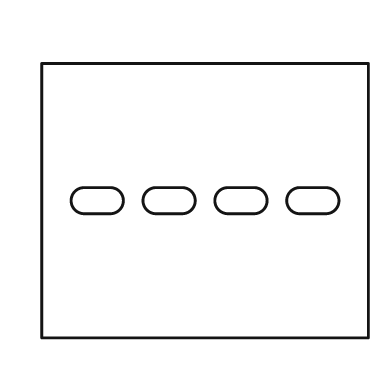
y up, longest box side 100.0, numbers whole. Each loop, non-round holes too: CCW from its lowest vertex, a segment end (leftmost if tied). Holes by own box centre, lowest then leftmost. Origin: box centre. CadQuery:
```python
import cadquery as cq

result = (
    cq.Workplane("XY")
    .moveTo(-50.0, -42.0)
    .lineTo(50.0, -42.0)
    .lineTo(50.0, 42.0)
    .lineTo(-50.0, 42.0)
    .close()
    .moveTo(-37.0, -4.0)
    .lineTo(-29.0, -4.0)
    .threePointArc((-25.0, 0.0), (-29.0, 4.0))
    .lineTo(-37.0, 4.0)
    .threePointArc((-41.0, 0.0), (-37.0, -4.0))
    .close()
    .moveTo(-15.0, -4.0)
    .lineTo(-7.0, -4.0)
    .threePointArc((-3.0, 0.0), (-7.0, 4.0))
    .lineTo(-15.0, 4.0)
    .threePointArc((-19.0, 0.0), (-15.0, -4.0))
    .close()
    .moveTo(7.0, -4.0)
    .lineTo(15.0, -4.0)
    .threePointArc((19.0, 0.0), (15.0, 4.0))
    .lineTo(7.0, 4.0)
    .threePointArc((3.0, 0.0), (7.0, -4.0))
    .close()
    .moveTo(29.0, -4.0)
    .lineTo(37.0, -4.0)
    .threePointArc((41.0, 0.0), (37.0, 4.0))
    .lineTo(29.0, 4.0)
    .threePointArc((25.0, 0.0), (29.0, -4.0))
    .close()
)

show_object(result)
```